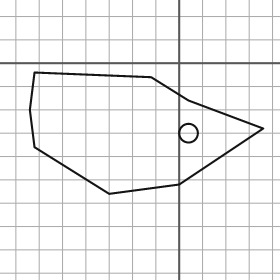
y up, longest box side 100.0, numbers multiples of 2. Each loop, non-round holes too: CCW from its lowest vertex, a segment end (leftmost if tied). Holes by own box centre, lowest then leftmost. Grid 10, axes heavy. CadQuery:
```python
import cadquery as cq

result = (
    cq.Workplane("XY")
    .moveTo(-30.0, -56.0)
    .lineTo(0.0, -52.0)
    .lineTo(36.0, -28.0)
    .lineTo(4.0, -16.0)
    .lineTo(-12.0, -6.0)
    .lineTo(-62.0, -4.0)
    .lineTo(-64.0, -20.0)
    .lineTo(-62.0, -36.0)
    .close()
    .moveTo(4.0, -30.0)
    .circle(4.0)
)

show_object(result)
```